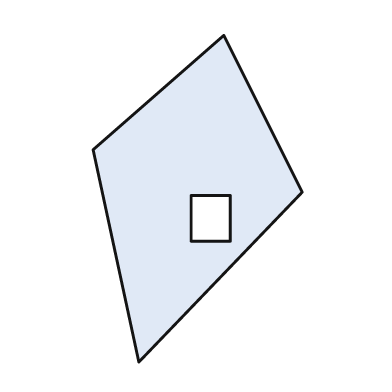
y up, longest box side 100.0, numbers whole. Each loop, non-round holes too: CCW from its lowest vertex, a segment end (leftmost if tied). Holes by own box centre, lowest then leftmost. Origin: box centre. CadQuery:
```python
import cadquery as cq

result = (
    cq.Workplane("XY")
    .moveTo(-18.0, -50.0)
    .lineTo(32.0, 2.0)
    .lineTo(8.0, 50.0)
    .lineTo(-32.0, 15.0)
    .close()
    .moveTo(-2.0, -13.0)
    .lineTo(10.0, -13.0)
    .lineTo(10.0, 1.0)
    .lineTo(-2.0, 1.0)
    .close()
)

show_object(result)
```